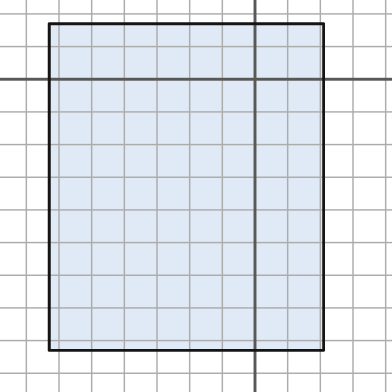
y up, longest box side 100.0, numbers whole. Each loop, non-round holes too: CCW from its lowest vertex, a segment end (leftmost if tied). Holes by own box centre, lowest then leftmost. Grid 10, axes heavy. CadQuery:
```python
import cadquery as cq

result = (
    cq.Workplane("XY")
    .moveTo(-63.0, -83.0)
    .lineTo(21.0, -83.0)
    .lineTo(21.0, 17.0)
    .lineTo(-63.0, 17.0)
    .close()
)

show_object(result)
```